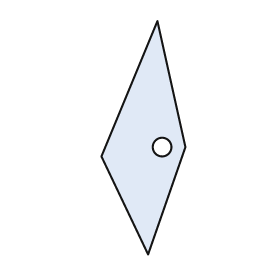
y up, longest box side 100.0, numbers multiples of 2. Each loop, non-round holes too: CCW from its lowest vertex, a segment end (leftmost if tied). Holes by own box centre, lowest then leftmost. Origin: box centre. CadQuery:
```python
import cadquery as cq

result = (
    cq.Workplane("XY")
    .moveTo(2.0, -50.0)
    .lineTo(18.0, -4.0)
    .lineTo(6.0, 50.0)
    .lineTo(-18.0, -8.0)
    .close()
    .moveTo(8.0, -4.0)
    .circle(4.0)
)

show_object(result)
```